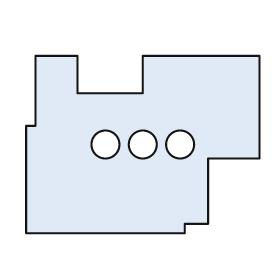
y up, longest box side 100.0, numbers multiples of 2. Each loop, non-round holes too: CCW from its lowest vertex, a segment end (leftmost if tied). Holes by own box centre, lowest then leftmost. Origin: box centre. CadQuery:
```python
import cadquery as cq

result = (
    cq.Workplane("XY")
    .moveTo(-50.0, -38.0)
    .lineTo(18.0, -38.0)
    .lineTo(18.0, -34.0)
    .lineTo(28.0, -34.0)
    .lineTo(28.0, -6.0)
    .lineTo(50.0, -6.0)
    .lineTo(50.0, 38.0)
    .lineTo(0.0, 38.0)
    .lineTo(0.0, 22.0)
    .lineTo(-28.0, 22.0)
    .lineTo(-28.0, 38.0)
    .lineTo(-46.0, 38.0)
    .lineTo(-46.0, 8.0)
    .lineTo(-50.0, 8.0)
    .close()
    .moveTo(-16.0, 0.0)
    .circle(6.0)
    .moveTo(0.0, 0.0)
    .circle(6.0)
    .moveTo(16.0, 0.0)
    .circle(6.0)
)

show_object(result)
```